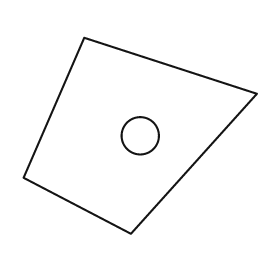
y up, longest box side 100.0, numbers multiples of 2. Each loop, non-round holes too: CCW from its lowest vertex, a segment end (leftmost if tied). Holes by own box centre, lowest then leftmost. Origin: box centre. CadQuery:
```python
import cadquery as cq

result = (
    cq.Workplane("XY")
    .moveTo(-4.0, -42.0)
    .lineTo(50.0, 18.0)
    .lineTo(-24.0, 42.0)
    .lineTo(-50.0, -18.0)
    .close()
    .moveTo(0.0, 0.0)
    .circle(8.0)
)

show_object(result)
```